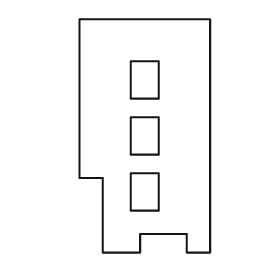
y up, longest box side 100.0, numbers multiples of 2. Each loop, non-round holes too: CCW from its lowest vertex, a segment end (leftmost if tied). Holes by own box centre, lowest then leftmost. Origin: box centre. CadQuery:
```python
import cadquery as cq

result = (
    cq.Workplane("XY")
    .moveTo(-18.0, -50.0)
    .lineTo(-2.0, -50.0)
    .lineTo(-2.0, -42.0)
    .lineTo(18.0, -42.0)
    .lineTo(18.0, -50.0)
    .lineTo(28.0, -50.0)
    .lineTo(28.0, 50.0)
    .lineTo(-28.0, 50.0)
    .lineTo(-28.0, -18.0)
    .lineTo(-18.0, -18.0)
    .close()
    .moveTo(-6.0, -32.0)
    .lineTo(6.0, -32.0)
    .lineTo(6.0, -16.0)
    .lineTo(-6.0, -16.0)
    .close()
    .moveTo(-6.0, -8.0)
    .lineTo(6.0, -8.0)
    .lineTo(6.0, 8.0)
    .lineTo(-6.0, 8.0)
    .close()
    .moveTo(-6.0, 16.0)
    .lineTo(6.0, 16.0)
    .lineTo(6.0, 32.0)
    .lineTo(-6.0, 32.0)
    .close()
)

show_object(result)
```